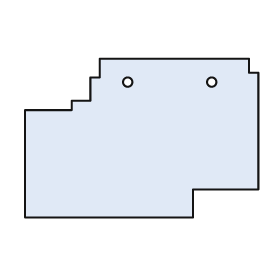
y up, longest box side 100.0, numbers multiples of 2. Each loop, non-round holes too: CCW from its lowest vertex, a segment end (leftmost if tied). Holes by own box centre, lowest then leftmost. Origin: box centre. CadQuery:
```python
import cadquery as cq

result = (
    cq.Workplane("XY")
    .moveTo(-50.0, -34.0)
    .lineTo(22.0, -34.0)
    .lineTo(22.0, -22.0)
    .lineTo(50.0, -22.0)
    .lineTo(50.0, 28.0)
    .lineTo(46.0, 28.0)
    .lineTo(46.0, 34.0)
    .lineTo(-18.0, 34.0)
    .lineTo(-18.0, 26.0)
    .lineTo(-22.0, 26.0)
    .lineTo(-22.0, 16.0)
    .lineTo(-30.0, 16.0)
    .lineTo(-30.0, 12.0)
    .lineTo(-50.0, 12.0)
    .close()
    .moveTo(-6.0, 24.0)
    .circle(2.0)
    .moveTo(30.0, 24.0)
    .circle(2.0)
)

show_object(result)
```